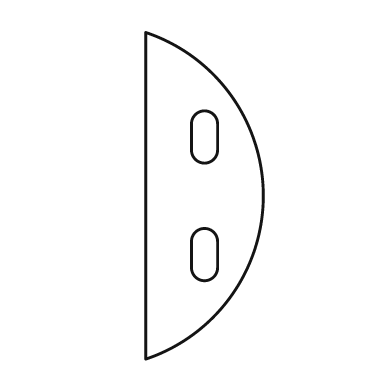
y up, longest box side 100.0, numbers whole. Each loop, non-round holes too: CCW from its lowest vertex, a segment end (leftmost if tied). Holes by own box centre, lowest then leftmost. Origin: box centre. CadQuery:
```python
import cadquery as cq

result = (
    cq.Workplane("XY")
    .moveTo(-18.0, -50.0)
    .threePointArc((18.0, 0.0), (-18.0, 50.0))
    .close()
    .moveTo(-4.0, -22.0)
    .threePointArc((0.0, -26.0), (4.0, -22.0))
    .lineTo(4.0, -14.0)
    .threePointArc((0.0, -10.0), (-4.0, -14.0))
    .close()
    .moveTo(-4.0, 14.0)
    .threePointArc((0.0, 10.0), (4.0, 14.0))
    .lineTo(4.0, 22.0)
    .threePointArc((0.0, 26.0), (-4.0, 22.0))
    .close()
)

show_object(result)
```